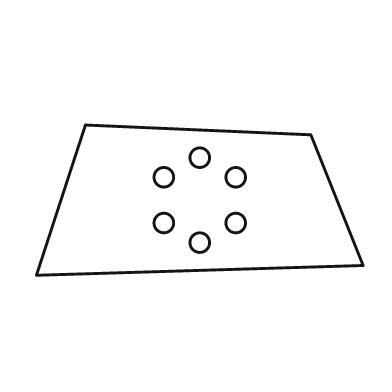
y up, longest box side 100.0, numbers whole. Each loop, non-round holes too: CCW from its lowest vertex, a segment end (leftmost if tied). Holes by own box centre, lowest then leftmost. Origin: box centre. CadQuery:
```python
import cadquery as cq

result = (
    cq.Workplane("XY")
    .moveTo(-50.0, -23.0)
    .lineTo(50.0, -20.0)
    .lineTo(34.0, 20.0)
    .lineTo(-35.0, 23.0)
    .close()
    .moveTo(0.0, -13.0)
    .circle(3.0)
    .moveTo(-11.0, -7.0)
    .circle(3.0)
    .moveTo(11.0, -7.0)
    .circle(3.0)
    .moveTo(-11.0, 7.0)
    .circle(3.0)
    .moveTo(11.0, 7.0)
    .circle(3.0)
    .moveTo(0.0, 13.0)
    .circle(3.0)
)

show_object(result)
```